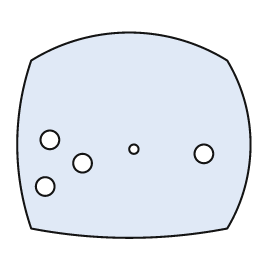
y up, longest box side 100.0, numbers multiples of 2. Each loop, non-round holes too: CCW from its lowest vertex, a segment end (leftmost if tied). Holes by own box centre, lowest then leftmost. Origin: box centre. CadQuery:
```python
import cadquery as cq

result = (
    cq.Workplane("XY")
    .moveTo(-44.0, -40.0)
    .threePointArc((-2.0, -44.0), (40.0, -40.0))
    .threePointArc((50.0, -4.0), (40.0, 32.0))
    .threePointArc((-2.0, 44.0), (-44.0, 32.0))
    .threePointArc((-50.0, -4.0), (-44.0, -40.0))
    .close()
    .moveTo(-38.0, -22.0)
    .circle(4.0)
    .moveTo(-22.0, -12.0)
    .circle(4.0)
    .moveTo(30.0, -8.0)
    .circle(4.0)
    .moveTo(0.0, -6.0)
    .circle(2.0)
    .moveTo(-36.0, -2.0)
    .circle(4.0)
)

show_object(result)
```